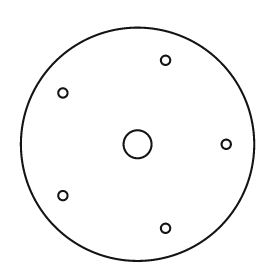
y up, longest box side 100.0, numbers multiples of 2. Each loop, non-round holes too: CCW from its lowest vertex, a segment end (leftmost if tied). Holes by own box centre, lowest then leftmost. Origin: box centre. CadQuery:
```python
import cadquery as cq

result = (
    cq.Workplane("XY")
    .moveTo(0.0, 0.0)
    .circle(50.0)
    .moveTo(12.0, -36.0)
    .circle(2.0)
    .moveTo(-32.0, -22.0)
    .circle(2.0)
    .moveTo(0.0, 0.0)
    .circle(6.0)
    .moveTo(38.0, 0.0)
    .circle(2.0)
    .moveTo(-32.0, 22.0)
    .circle(2.0)
    .moveTo(12.0, 36.0)
    .circle(2.0)
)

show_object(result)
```